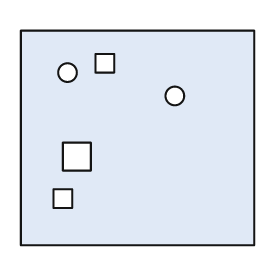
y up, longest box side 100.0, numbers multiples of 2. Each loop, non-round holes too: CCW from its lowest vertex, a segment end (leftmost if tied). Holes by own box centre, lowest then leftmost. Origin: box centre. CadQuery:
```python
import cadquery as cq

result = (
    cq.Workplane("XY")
    .moveTo(-50.0, -46.0)
    .lineTo(50.0, -46.0)
    .lineTo(50.0, 46.0)
    .lineTo(-50.0, 46.0)
    .close()
    .moveTo(-36.0, -30.0)
    .lineTo(-28.0, -30.0)
    .lineTo(-28.0, -22.0)
    .lineTo(-36.0, -22.0)
    .close()
    .moveTo(-32.0, -14.0)
    .lineTo(-20.0, -14.0)
    .lineTo(-20.0, -2.0)
    .lineTo(-32.0, -2.0)
    .close()
    .moveTo(16.0, 18.0)
    .circle(4.0)
    .moveTo(-30.0, 28.0)
    .circle(4.0)
    .moveTo(-18.0, 28.0)
    .lineTo(-10.0, 28.0)
    .lineTo(-10.0, 36.0)
    .lineTo(-18.0, 36.0)
    .close()
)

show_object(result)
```